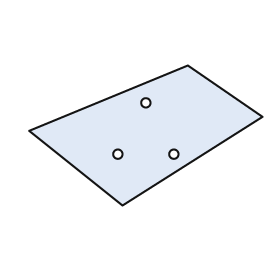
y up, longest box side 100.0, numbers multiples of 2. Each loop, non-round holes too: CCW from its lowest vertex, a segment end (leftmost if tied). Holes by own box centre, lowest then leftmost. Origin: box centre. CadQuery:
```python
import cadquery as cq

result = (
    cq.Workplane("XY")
    .moveTo(-10.0, -30.0)
    .lineTo(50.0, 8.0)
    .lineTo(18.0, 30.0)
    .lineTo(-50.0, 2.0)
    .close()
    .moveTo(-12.0, -8.0)
    .circle(2.0)
    .moveTo(12.0, -8.0)
    .circle(2.0)
    .moveTo(0.0, 14.0)
    .circle(2.0)
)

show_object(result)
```